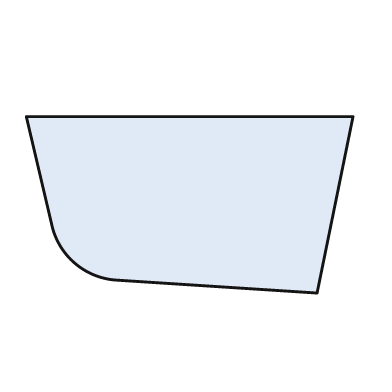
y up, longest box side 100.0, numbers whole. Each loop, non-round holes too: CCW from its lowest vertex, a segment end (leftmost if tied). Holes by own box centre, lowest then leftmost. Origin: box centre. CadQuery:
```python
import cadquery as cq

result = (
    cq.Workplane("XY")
    .moveTo(39.0, -27.0)
    .lineTo(50.0, 27.0)
    .lineTo(-50.0, 27.0)
    .lineTo(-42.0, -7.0)
    .threePointArc((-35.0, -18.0), (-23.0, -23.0))
    .close()
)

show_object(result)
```